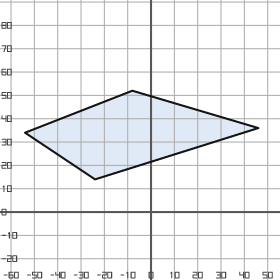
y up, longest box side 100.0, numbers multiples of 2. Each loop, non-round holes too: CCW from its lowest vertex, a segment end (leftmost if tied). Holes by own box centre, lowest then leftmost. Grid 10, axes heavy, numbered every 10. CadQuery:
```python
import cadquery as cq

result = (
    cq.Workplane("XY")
    .moveTo(-24.0, 14.0)
    .lineTo(46.0, 36.0)
    .lineTo(-8.0, 52.0)
    .lineTo(-54.0, 34.0)
    .close()
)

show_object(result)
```